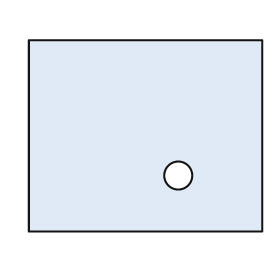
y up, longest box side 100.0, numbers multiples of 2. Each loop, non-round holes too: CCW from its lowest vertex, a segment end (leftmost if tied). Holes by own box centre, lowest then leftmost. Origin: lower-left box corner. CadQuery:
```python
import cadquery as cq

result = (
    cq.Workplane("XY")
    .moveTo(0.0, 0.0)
    .lineTo(100.0, 0.0)
    .lineTo(100.0, 82.0)
    .lineTo(0.0, 82.0)
    .close()
    .moveTo(64.0, 24.0)
    .circle(6.0)
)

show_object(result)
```